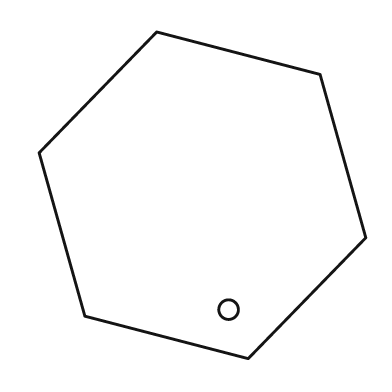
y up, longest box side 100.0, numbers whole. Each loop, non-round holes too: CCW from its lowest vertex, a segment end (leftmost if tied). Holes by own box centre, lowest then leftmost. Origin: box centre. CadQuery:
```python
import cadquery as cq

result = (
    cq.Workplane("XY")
    .moveTo(14.0, -50.0)
    .lineTo(50.0, -13.0)
    .lineTo(36.0, 37.0)
    .lineTo(-14.0, 50.0)
    .lineTo(-50.0, 13.0)
    .lineTo(-36.0, -37.0)
    .close()
    .moveTo(8.0, -35.0)
    .circle(3.0)
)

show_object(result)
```